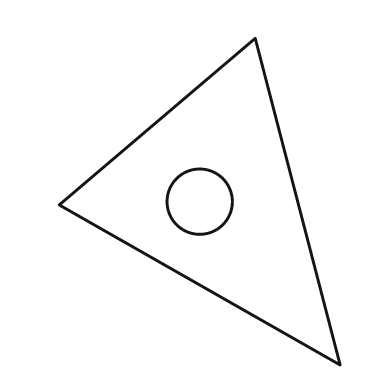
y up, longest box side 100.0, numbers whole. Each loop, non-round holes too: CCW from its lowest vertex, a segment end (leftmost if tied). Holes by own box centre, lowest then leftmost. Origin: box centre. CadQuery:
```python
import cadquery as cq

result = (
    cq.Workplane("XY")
    .moveTo(43.0, -50.0)
    .lineTo(17.0, 50.0)
    .lineTo(-43.0, -1.0)
    .close()
    .moveTo(0.0, 0.0)
    .circle(10.0)
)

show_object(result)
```